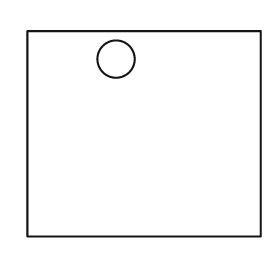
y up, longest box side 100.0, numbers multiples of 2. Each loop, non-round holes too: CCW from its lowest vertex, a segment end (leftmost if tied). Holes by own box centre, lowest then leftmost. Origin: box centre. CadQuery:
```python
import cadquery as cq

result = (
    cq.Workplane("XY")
    .moveTo(-50.0, -44.0)
    .lineTo(50.0, -44.0)
    .lineTo(50.0, 44.0)
    .lineTo(-50.0, 44.0)
    .close()
    .moveTo(-12.0, 32.0)
    .circle(8.0)
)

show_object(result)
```